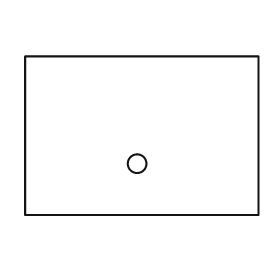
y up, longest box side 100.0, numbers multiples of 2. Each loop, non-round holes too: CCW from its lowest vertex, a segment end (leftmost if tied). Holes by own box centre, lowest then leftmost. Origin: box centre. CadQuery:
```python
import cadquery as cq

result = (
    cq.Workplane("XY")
    .moveTo(-50.0, -34.0)
    .lineTo(50.0, -34.0)
    .lineTo(50.0, 34.0)
    .lineTo(-50.0, 34.0)
    .close()
    .moveTo(-2.0, -12.0)
    .circle(4.0)
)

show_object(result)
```